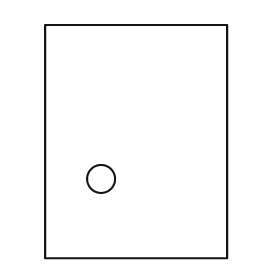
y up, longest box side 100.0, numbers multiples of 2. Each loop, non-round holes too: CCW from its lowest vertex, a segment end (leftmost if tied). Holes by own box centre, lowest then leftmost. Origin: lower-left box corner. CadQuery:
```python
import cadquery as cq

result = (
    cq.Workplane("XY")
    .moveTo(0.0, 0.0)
    .lineTo(78.0, 0.0)
    .lineTo(78.0, 100.0)
    .lineTo(0.0, 100.0)
    .close()
    .moveTo(24.0, 34.0)
    .circle(6.0)
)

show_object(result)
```